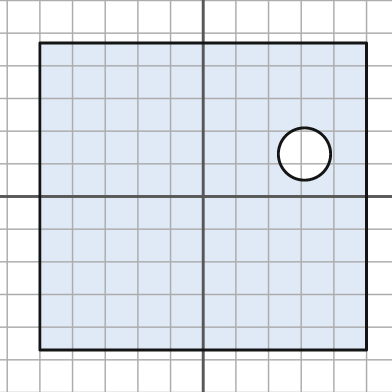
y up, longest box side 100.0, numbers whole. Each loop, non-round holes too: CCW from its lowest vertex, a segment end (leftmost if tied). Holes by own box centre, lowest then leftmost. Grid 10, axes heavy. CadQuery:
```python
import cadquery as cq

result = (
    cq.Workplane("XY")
    .moveTo(-50.0, -47.0)
    .lineTo(50.0, -47.0)
    .lineTo(50.0, 47.0)
    .lineTo(-50.0, 47.0)
    .close()
    .moveTo(31.0, 13.0)
    .circle(8.0)
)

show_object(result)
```